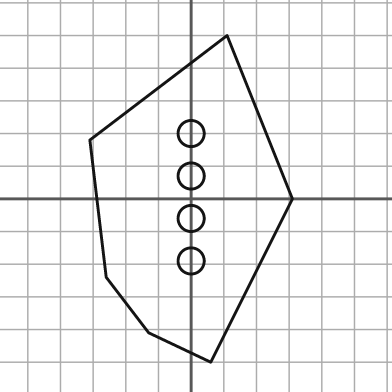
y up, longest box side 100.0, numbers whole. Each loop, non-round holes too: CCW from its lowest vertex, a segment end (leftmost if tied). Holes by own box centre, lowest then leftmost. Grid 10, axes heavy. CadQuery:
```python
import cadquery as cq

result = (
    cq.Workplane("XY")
    .moveTo(6.0, -50.0)
    .lineTo(31.0, 0.0)
    .lineTo(11.0, 50.0)
    .lineTo(-31.0, 18.0)
    .lineTo(-26.0, -24.0)
    .lineTo(-13.0, -41.0)
    .close()
    .moveTo(0.0, -19.0)
    .circle(4.0)
    .moveTo(0.0, -6.0)
    .circle(4.0)
    .moveTo(0.0, 7.0)
    .circle(4.0)
    .moveTo(0.0, 20.0)
    .circle(4.0)
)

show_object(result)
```